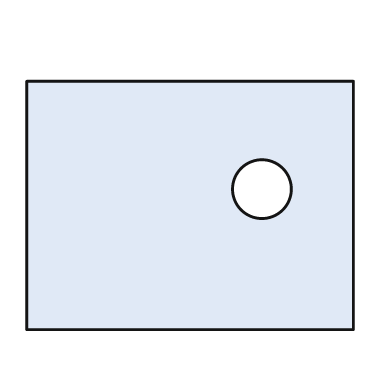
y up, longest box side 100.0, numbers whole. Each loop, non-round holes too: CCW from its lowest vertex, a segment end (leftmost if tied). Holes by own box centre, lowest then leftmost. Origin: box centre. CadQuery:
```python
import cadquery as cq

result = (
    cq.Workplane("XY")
    .moveTo(-50.0, -38.0)
    .lineTo(50.0, -38.0)
    .lineTo(50.0, 38.0)
    .lineTo(-50.0, 38.0)
    .close()
    .moveTo(22.0, 5.0)
    .circle(9.0)
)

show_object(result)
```